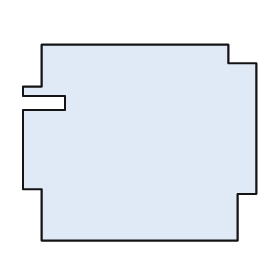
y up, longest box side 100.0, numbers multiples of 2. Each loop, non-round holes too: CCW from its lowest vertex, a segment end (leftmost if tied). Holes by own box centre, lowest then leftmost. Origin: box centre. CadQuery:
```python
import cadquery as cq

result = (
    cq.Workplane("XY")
    .moveTo(-42.0, -42.0)
    .lineTo(42.0, -42.0)
    .lineTo(42.0, -22.0)
    .lineTo(50.0, -22.0)
    .lineTo(50.0, 34.0)
    .lineTo(38.0, 34.0)
    .lineTo(38.0, 42.0)
    .lineTo(-42.0, 42.0)
    .lineTo(-42.0, 24.0)
    .lineTo(-50.0, 24.0)
    .lineTo(-50.0, 20.0)
    .lineTo(-32.0, 20.0)
    .lineTo(-32.0, 14.0)
    .lineTo(-50.0, 14.0)
    .lineTo(-50.0, -20.0)
    .lineTo(-42.0, -20.0)
    .close()
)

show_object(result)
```